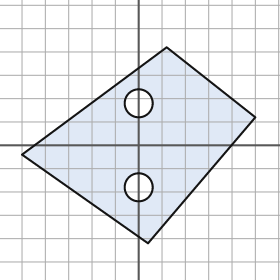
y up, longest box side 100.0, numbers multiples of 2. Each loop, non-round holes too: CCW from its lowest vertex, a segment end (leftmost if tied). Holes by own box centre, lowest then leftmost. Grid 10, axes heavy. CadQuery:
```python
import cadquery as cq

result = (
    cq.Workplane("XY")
    .moveTo(4.0, -42.0)
    .lineTo(50.0, 12.0)
    .lineTo(12.0, 42.0)
    .lineTo(-50.0, -4.0)
    .close()
    .moveTo(0.0, -18.0)
    .circle(6.0)
    .moveTo(0.0, 18.0)
    .circle(6.0)
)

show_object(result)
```